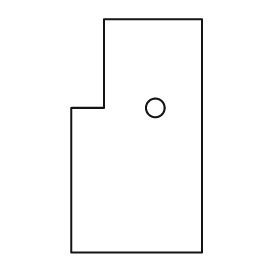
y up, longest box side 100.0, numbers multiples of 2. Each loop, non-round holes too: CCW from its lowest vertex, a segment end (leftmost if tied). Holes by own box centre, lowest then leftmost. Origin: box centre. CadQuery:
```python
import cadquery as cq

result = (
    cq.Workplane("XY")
    .moveTo(-28.0, -50.0)
    .lineTo(28.0, -50.0)
    .lineTo(28.0, 50.0)
    .lineTo(-14.0, 50.0)
    .lineTo(-14.0, 12.0)
    .lineTo(-28.0, 12.0)
    .close()
    .moveTo(8.0, 12.0)
    .circle(4.0)
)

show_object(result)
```